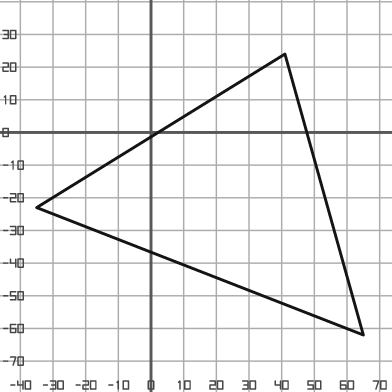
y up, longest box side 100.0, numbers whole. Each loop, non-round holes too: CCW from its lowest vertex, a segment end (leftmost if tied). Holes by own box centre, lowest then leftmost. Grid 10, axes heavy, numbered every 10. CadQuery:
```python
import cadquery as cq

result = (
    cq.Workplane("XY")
    .moveTo(65.0, -62.0)
    .lineTo(41.0, 24.0)
    .lineTo(-35.0, -23.0)
    .close()
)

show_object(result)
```